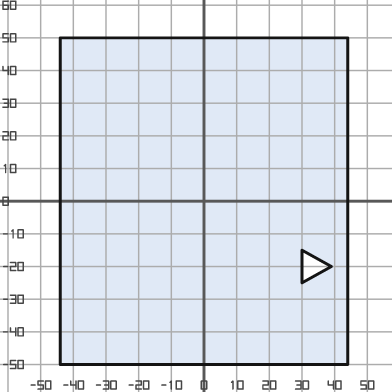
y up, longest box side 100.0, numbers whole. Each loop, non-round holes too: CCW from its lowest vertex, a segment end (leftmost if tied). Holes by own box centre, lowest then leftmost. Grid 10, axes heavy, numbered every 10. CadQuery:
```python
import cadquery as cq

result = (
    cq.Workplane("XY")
    .moveTo(-44.0, -50.0)
    .lineTo(44.0, -50.0)
    .lineTo(44.0, 50.0)
    .lineTo(-44.0, 50.0)
    .close()
    .moveTo(30.0, -25.0)
    .lineTo(39.0, -20.0)
    .lineTo(30.0, -15.0)
    .close()
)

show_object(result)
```